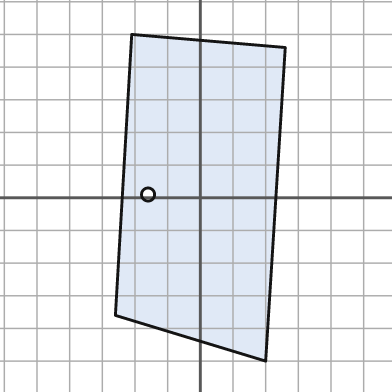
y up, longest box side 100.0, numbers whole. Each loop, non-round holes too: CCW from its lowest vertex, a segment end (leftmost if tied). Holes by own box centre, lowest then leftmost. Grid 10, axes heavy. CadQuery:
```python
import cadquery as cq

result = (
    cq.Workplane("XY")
    .moveTo(20.0, -50.0)
    .lineTo(26.0, 46.0)
    .lineTo(-21.0, 50.0)
    .lineTo(-26.0, -36.0)
    .close()
    .moveTo(-16.0, 1.0)
    .circle(2.0)
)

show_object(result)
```